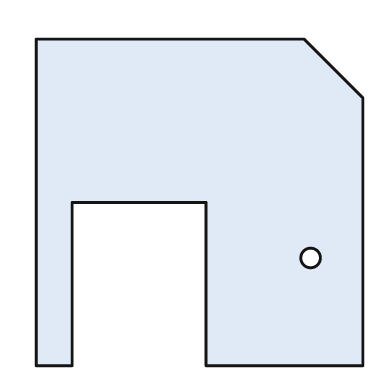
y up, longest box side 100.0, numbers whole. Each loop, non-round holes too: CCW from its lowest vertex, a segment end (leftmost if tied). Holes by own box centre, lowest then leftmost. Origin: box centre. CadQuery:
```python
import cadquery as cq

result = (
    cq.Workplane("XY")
    .moveTo(-50.0, -50.0)
    .lineTo(-39.0, -50.0)
    .lineTo(-39.0, 0.0)
    .lineTo(2.0, 0.0)
    .lineTo(2.0, -50.0)
    .lineTo(50.0, -50.0)
    .lineTo(50.0, 32.0)
    .lineTo(32.0, 50.0)
    .lineTo(-50.0, 50.0)
    .close()
    .moveTo(34.0, -17.0)
    .circle(3.0)
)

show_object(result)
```